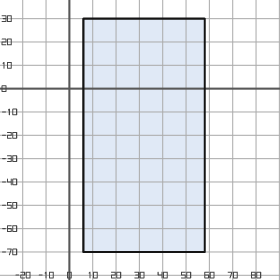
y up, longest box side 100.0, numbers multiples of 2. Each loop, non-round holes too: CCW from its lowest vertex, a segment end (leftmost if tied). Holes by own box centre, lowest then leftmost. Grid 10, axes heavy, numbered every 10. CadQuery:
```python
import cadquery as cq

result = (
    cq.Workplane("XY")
    .moveTo(6.0, -70.0)
    .lineTo(58.0, -70.0)
    .lineTo(58.0, 30.0)
    .lineTo(6.0, 30.0)
    .close()
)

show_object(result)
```